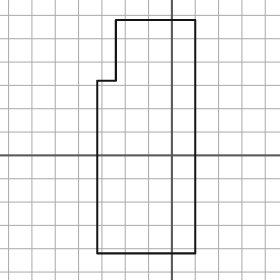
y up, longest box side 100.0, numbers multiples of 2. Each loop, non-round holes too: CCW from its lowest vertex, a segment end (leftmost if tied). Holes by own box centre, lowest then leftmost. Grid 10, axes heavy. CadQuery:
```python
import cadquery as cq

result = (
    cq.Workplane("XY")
    .moveTo(-32.0, -42.0)
    .lineTo(10.0, -42.0)
    .lineTo(10.0, 58.0)
    .lineTo(-24.0, 58.0)
    .lineTo(-24.0, 32.0)
    .lineTo(-32.0, 32.0)
    .close()
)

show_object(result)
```